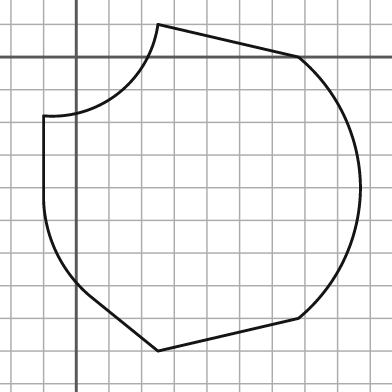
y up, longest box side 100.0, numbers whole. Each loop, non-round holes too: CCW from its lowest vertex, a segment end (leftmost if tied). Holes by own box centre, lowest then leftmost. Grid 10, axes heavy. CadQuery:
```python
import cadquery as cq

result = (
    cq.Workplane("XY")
    .moveTo(25.0, -90.0)
    .lineTo(68.0, -80.0)
    .threePointArc((82.0, -62.0), (87.0, -40.0))
    .threePointArc((82.0, -18.0), (68.0, 0.0))
    .lineTo(25.0, 10.0)
    .threePointArc((13.0, -11.0), (-10.0, -18.0))
    .lineTo(-10.0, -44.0)
    .threePointArc((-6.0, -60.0), (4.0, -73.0))
    .close()
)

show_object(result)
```